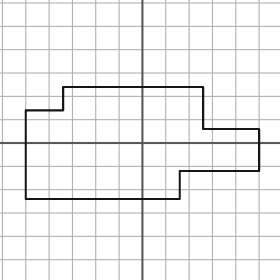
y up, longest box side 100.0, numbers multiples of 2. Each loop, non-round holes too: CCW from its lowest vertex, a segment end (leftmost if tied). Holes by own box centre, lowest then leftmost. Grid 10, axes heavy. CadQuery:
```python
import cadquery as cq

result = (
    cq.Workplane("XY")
    .moveTo(-50.0, -24.0)
    .lineTo(16.0, -24.0)
    .lineTo(16.0, -12.0)
    .lineTo(50.0, -12.0)
    .lineTo(50.0, 6.0)
    .lineTo(26.0, 6.0)
    .lineTo(26.0, 24.0)
    .lineTo(-34.0, 24.0)
    .lineTo(-34.0, 14.0)
    .lineTo(-50.0, 14.0)
    .close()
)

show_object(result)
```